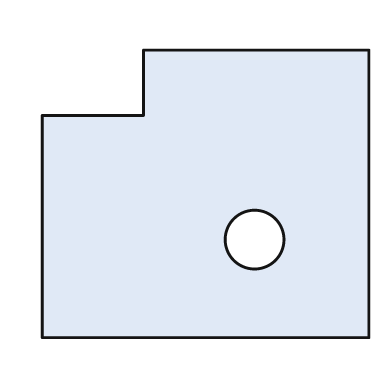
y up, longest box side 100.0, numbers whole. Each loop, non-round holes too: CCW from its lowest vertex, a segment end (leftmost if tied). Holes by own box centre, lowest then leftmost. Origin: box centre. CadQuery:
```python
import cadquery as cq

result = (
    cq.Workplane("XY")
    .moveTo(-50.0, -44.0)
    .lineTo(50.0, -44.0)
    .lineTo(50.0, 44.0)
    .lineTo(-19.0, 44.0)
    .lineTo(-19.0, 24.0)
    .lineTo(-50.0, 24.0)
    .close()
    .moveTo(15.0, -14.0)
    .circle(9.0)
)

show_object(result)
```